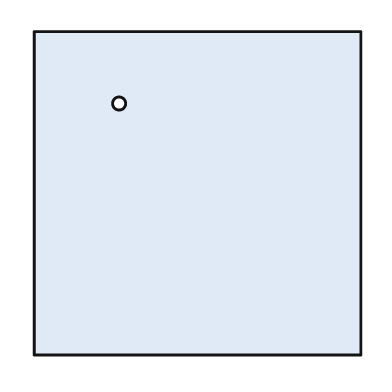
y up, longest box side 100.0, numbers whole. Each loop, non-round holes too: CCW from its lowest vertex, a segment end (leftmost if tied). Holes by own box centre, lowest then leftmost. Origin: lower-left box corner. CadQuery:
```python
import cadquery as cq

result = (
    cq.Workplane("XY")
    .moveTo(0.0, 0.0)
    .lineTo(100.0, 0.0)
    .lineTo(100.0, 99.0)
    .lineTo(0.0, 99.0)
    .close()
    .moveTo(26.0, 77.0)
    .circle(2.0)
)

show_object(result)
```